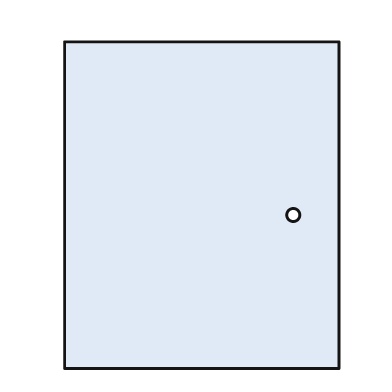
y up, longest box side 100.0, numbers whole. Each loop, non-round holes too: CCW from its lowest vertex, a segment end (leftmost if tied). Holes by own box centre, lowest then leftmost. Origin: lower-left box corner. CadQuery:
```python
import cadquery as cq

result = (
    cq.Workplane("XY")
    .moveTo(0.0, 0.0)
    .lineTo(84.0, 0.0)
    .lineTo(84.0, 100.0)
    .lineTo(0.0, 100.0)
    .close()
    .moveTo(70.0, 47.0)
    .circle(2.0)
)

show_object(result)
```